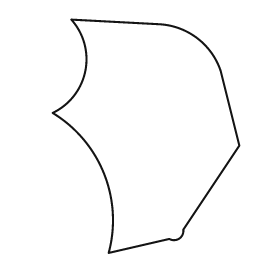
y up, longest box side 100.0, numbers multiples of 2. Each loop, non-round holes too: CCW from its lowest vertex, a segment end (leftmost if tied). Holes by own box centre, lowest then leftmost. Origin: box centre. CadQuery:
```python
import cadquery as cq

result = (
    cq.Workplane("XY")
    .moveTo(-16.0, -50.0)
    .lineTo(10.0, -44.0)
    .threePointArc((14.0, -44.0), (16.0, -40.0))
    .lineTo(40.0, -4.0)
    .lineTo(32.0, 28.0)
    .threePointArc((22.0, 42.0), (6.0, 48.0))
    .lineTo(-32.0, 50.0)
    .threePointArc((-26.0, 28.0), (-40.0, 10.0))
    .threePointArc((-18.0, -16.0), (-16.0, -50.0))
    .close()
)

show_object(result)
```